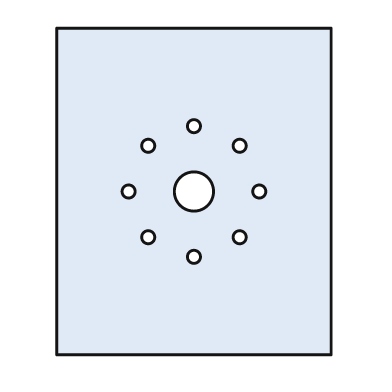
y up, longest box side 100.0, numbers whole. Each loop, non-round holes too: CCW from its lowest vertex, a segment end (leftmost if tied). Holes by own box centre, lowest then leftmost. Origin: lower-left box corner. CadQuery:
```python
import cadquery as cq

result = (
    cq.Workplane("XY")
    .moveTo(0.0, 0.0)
    .lineTo(84.0, 0.0)
    .lineTo(84.0, 100.0)
    .lineTo(0.0, 100.0)
    .close()
    .moveTo(42.0, 30.0)
    .circle(2.0)
    .moveTo(28.0, 36.0)
    .circle(2.0)
    .moveTo(56.0, 36.0)
    .circle(2.0)
    .moveTo(22.0, 50.0)
    .circle(2.0)
    .moveTo(42.0, 50.0)
    .circle(6.0)
    .moveTo(62.0, 50.0)
    .circle(2.0)
    .moveTo(28.0, 64.0)
    .circle(2.0)
    .moveTo(56.0, 64.0)
    .circle(2.0)
    .moveTo(42.0, 70.0)
    .circle(2.0)
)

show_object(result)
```